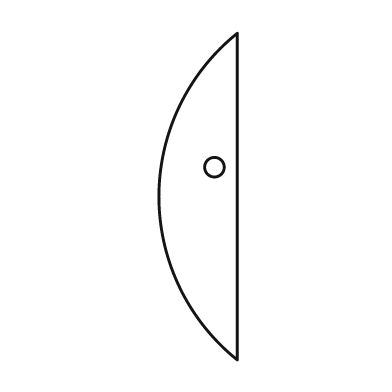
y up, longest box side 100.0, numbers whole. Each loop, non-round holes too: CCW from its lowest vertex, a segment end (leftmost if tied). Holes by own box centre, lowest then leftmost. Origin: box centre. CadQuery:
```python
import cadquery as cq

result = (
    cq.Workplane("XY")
    .moveTo(12.0, -50.0)
    .lineTo(12.0, 50.0)
    .threePointArc((-12.0, 0.0), (12.0, -50.0))
    .close()
    .moveTo(5.0, 9.0)
    .circle(3.0)
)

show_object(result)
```